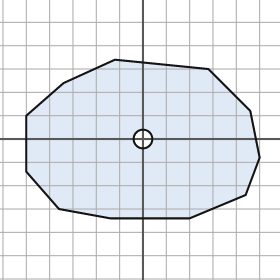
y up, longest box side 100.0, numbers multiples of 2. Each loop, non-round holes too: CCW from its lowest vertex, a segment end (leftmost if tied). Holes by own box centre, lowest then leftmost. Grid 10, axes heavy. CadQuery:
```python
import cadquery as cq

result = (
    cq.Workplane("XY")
    .moveTo(-14.0, -34.0)
    .lineTo(20.0, -34.0)
    .lineTo(44.0, -24.0)
    .lineTo(50.0, -8.0)
    .lineTo(46.0, 12.0)
    .lineTo(28.0, 30.0)
    .lineTo(-12.0, 34.0)
    .lineTo(-34.0, 24.0)
    .lineTo(-50.0, 10.0)
    .lineTo(-50.0, -14.0)
    .lineTo(-36.0, -30.0)
    .close()
    .moveTo(0.0, 0.0)
    .circle(4.0)
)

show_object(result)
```